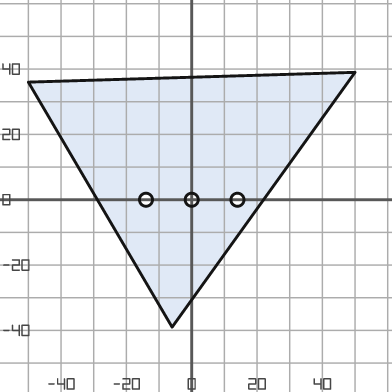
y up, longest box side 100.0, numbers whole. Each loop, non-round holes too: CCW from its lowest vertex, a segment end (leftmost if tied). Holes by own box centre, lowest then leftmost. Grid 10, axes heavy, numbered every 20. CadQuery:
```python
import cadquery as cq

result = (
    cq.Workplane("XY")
    .moveTo(-6.0, -39.0)
    .lineTo(50.0, 39.0)
    .lineTo(-50.0, 36.0)
    .close()
    .moveTo(-14.0, 0.0)
    .circle(2.0)
    .moveTo(0.0, 0.0)
    .circle(2.0)
    .moveTo(14.0, 0.0)
    .circle(2.0)
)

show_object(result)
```